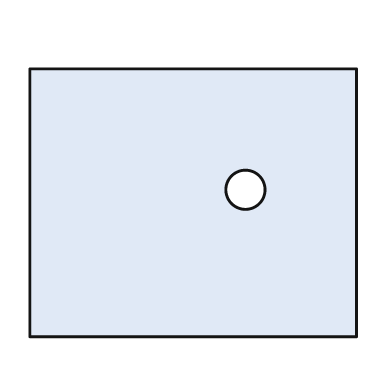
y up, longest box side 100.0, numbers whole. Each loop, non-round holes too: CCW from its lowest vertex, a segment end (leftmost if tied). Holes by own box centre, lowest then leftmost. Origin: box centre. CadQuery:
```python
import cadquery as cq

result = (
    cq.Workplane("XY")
    .moveTo(-50.0, -41.0)
    .lineTo(50.0, -41.0)
    .lineTo(50.0, 41.0)
    .lineTo(-50.0, 41.0)
    .close()
    .moveTo(16.0, 4.0)
    .circle(6.0)
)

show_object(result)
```